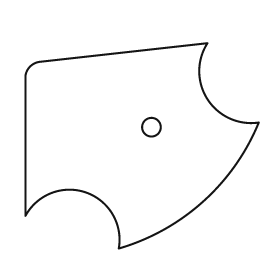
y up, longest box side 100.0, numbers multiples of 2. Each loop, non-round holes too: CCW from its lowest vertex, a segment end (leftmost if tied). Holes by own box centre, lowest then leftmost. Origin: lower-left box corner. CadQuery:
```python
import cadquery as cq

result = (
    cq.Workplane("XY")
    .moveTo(40.0, 0.0)
    .threePointArc((76.0, 20.0), (100.0, 54.0))
    .threePointArc((78.0, 64.0), (78.0, 88.0))
    .lineTo(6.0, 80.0)
    .threePointArc((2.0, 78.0), (0.0, 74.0))
    .lineTo(0.0, 14.0)
    .threePointArc((26.0, 24.0), (40.0, 0.0))
    .close()
    .moveTo(54.0, 52.0)
    .circle(4.0)
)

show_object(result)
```